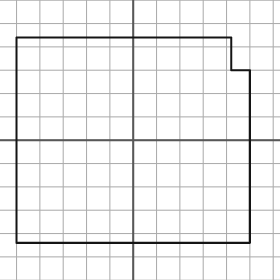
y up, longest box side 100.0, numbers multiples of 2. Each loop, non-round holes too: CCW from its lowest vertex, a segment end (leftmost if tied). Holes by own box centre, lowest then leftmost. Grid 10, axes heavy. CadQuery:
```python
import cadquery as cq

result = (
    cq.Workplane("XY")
    .moveTo(-50.0, -44.0)
    .lineTo(50.0, -44.0)
    .lineTo(50.0, 30.0)
    .lineTo(42.0, 30.0)
    .lineTo(42.0, 44.0)
    .lineTo(-50.0, 44.0)
    .close()
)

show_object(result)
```